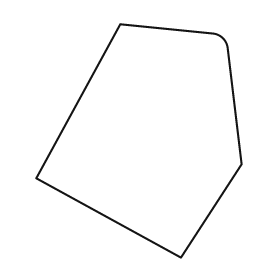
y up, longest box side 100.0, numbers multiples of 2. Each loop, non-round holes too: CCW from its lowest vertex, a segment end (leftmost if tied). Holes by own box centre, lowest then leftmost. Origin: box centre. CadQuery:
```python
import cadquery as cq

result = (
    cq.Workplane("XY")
    .moveTo(18.0, -50.0)
    .lineTo(44.0, -10.0)
    .lineTo(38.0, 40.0)
    .threePointArc((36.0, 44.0), (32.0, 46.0))
    .lineTo(-8.0, 50.0)
    .lineTo(-44.0, -16.0)
    .close()
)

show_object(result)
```